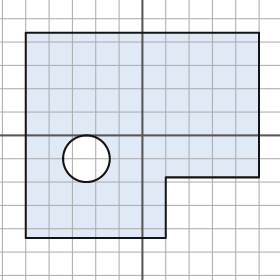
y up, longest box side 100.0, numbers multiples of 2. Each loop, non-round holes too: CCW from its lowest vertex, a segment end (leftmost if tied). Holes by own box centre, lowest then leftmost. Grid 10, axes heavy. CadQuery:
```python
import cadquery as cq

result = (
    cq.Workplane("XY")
    .moveTo(-50.0, -44.0)
    .lineTo(10.0, -44.0)
    .lineTo(10.0, -18.0)
    .lineTo(50.0, -18.0)
    .lineTo(50.0, 44.0)
    .lineTo(-50.0, 44.0)
    .close()
    .moveTo(-24.0, -10.0)
    .circle(10.0)
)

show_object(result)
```